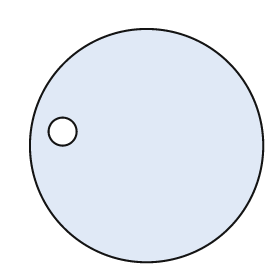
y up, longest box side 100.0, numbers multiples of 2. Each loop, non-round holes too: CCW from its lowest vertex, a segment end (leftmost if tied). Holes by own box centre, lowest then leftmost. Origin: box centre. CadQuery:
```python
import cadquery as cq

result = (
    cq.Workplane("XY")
    .moveTo(0.0, 0.0)
    .circle(50.0)
    .moveTo(-36.0, 6.0)
    .circle(6.0)
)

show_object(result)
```